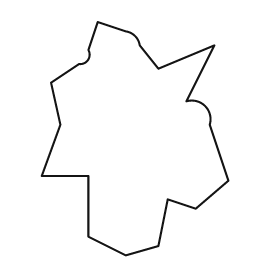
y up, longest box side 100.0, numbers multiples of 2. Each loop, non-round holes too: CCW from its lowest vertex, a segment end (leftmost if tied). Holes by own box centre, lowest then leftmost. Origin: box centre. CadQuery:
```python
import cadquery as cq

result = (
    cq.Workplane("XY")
    .moveTo(-4.0, -50.0)
    .lineTo(10.0, -46.0)
    .lineTo(14.0, -26.0)
    .lineTo(26.0, -30.0)
    .lineTo(40.0, -18.0)
    .lineTo(32.0, 6.0)
    .threePointArc((30.0, 14.0), (22.0, 16.0))
    .lineTo(34.0, 40.0)
    .lineTo(10.0, 30.0)
    .lineTo(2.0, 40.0)
    .threePointArc((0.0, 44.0), (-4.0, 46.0))
    .lineTo(-16.0, 50.0)
    .lineTo(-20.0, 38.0)
    .threePointArc((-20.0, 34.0), (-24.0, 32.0))
    .lineTo(-36.0, 24.0)
    .lineTo(-32.0, 6.0)
    .lineTo(-40.0, -16.0)
    .lineTo(-20.0, -16.0)
    .lineTo(-20.0, -42.0)
    .close()
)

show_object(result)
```